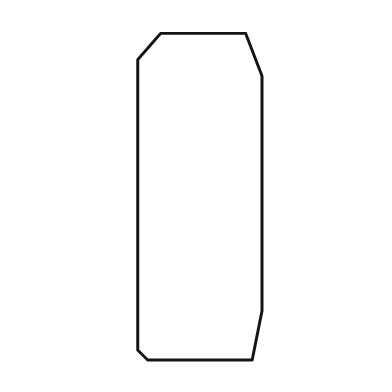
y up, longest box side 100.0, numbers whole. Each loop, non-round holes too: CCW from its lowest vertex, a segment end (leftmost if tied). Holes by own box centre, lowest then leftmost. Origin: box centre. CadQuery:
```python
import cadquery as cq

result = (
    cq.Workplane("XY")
    .moveTo(-16.0, -50.0)
    .lineTo(16.0, -50.0)
    .lineTo(19.0, -35.0)
    .lineTo(19.0, 37.0)
    .lineTo(14.0, 50.0)
    .lineTo(-12.0, 50.0)
    .lineTo(-19.0, 42.0)
    .lineTo(-19.0, -47.0)
    .close()
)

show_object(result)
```